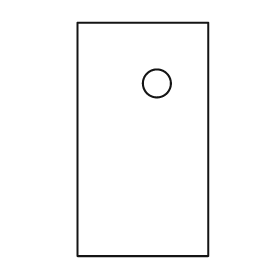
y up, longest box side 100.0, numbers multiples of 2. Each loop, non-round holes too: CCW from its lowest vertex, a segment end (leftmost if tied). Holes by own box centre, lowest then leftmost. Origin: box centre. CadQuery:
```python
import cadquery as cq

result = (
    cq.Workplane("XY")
    .moveTo(-28.0, -50.0)
    .lineTo(28.0, -50.0)
    .lineTo(28.0, 50.0)
    .lineTo(-28.0, 50.0)
    .close()
    .moveTo(6.0, 24.0)
    .circle(6.0)
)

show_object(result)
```